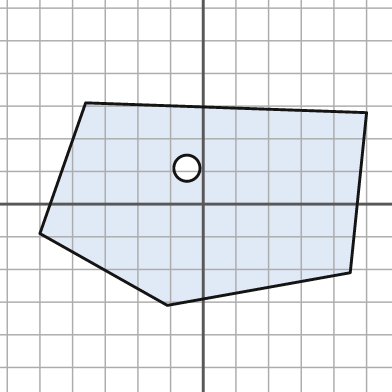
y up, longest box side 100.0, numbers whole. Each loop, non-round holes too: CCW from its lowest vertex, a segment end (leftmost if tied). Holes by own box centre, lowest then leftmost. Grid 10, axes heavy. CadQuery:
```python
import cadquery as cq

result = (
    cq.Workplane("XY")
    .moveTo(-11.0, -31.0)
    .lineTo(45.0, -21.0)
    .lineTo(50.0, 28.0)
    .lineTo(-36.0, 31.0)
    .lineTo(-50.0, -9.0)
    .close()
    .moveTo(-5.0, 11.0)
    .circle(4.0)
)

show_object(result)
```